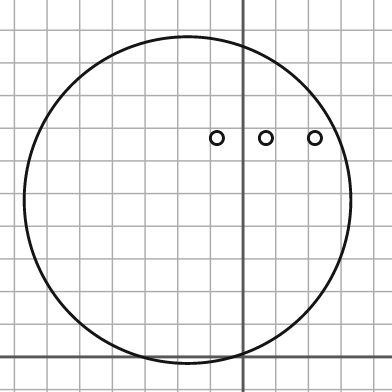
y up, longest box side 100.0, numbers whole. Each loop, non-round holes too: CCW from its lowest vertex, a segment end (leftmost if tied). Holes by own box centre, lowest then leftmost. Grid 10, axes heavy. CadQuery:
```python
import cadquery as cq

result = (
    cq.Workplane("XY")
    .moveTo(-17.0, 48.0)
    .circle(50.0)
    .moveTo(-8.0, 67.0)
    .circle(2.0)
    .moveTo(7.0, 67.0)
    .circle(2.0)
    .moveTo(22.0, 67.0)
    .circle(2.0)
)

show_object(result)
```